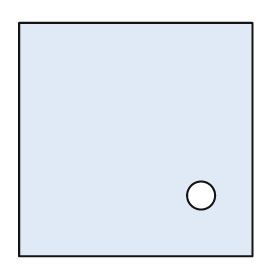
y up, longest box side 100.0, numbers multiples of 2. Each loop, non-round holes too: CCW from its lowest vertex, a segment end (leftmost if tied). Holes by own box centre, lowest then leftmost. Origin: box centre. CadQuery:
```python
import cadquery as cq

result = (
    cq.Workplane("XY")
    .moveTo(-50.0, -50.0)
    .lineTo(50.0, -50.0)
    .lineTo(50.0, 50.0)
    .lineTo(-50.0, 50.0)
    .close()
    .moveTo(28.0, -24.0)
    .circle(6.0)
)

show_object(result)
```